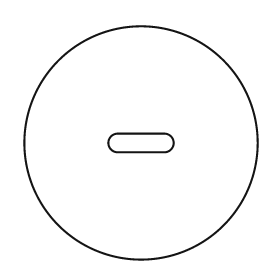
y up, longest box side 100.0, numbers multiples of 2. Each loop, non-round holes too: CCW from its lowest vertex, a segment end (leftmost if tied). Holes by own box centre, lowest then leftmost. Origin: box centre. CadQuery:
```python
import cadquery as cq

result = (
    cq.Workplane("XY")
    .moveTo(0.0, 0.0)
    .circle(50.0)
    .moveTo(-10.0, -4.0)
    .lineTo(10.0, -4.0)
    .threePointArc((14.0, 0.0), (10.0, 4.0))
    .lineTo(-10.0, 4.0)
    .threePointArc((-14.0, 0.0), (-10.0, -4.0))
    .close()
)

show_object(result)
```